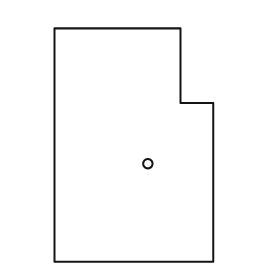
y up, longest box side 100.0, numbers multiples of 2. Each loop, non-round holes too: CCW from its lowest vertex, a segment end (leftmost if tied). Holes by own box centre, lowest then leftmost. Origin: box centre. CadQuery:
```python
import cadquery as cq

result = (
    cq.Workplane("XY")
    .moveTo(-34.0, -50.0)
    .lineTo(34.0, -50.0)
    .lineTo(34.0, 18.0)
    .lineTo(20.0, 18.0)
    .lineTo(20.0, 50.0)
    .lineTo(-34.0, 50.0)
    .close()
    .moveTo(6.0, -8.0)
    .circle(2.0)
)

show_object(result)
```